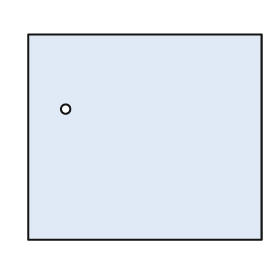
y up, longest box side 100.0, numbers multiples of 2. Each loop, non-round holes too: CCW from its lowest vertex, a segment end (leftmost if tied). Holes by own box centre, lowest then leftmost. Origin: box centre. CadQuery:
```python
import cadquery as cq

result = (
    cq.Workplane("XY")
    .moveTo(-50.0, -44.0)
    .lineTo(50.0, -44.0)
    .lineTo(50.0, 44.0)
    .lineTo(-50.0, 44.0)
    .close()
    .moveTo(-34.0, 12.0)
    .circle(2.0)
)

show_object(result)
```